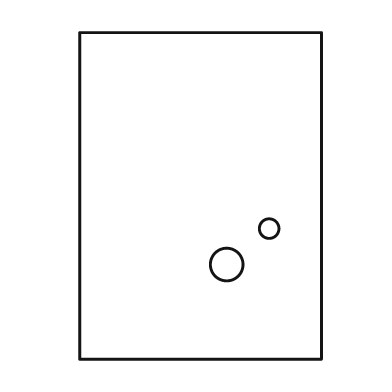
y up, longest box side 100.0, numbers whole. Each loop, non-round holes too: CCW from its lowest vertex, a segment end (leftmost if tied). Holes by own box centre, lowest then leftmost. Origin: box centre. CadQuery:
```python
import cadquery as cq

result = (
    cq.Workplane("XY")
    .moveTo(-37.0, -50.0)
    .lineTo(37.0, -50.0)
    .lineTo(37.0, 50.0)
    .lineTo(-37.0, 50.0)
    .close()
    .moveTo(8.0, -21.0)
    .circle(5.0)
    .moveTo(21.0, -10.0)
    .circle(3.0)
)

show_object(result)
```